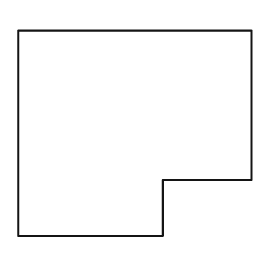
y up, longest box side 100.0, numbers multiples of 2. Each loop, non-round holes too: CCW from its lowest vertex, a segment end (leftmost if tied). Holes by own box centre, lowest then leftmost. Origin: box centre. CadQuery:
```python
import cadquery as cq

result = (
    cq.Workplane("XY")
    .moveTo(-50.0, -44.0)
    .lineTo(12.0, -44.0)
    .lineTo(12.0, -20.0)
    .lineTo(50.0, -20.0)
    .lineTo(50.0, 44.0)
    .lineTo(-50.0, 44.0)
    .close()
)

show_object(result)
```